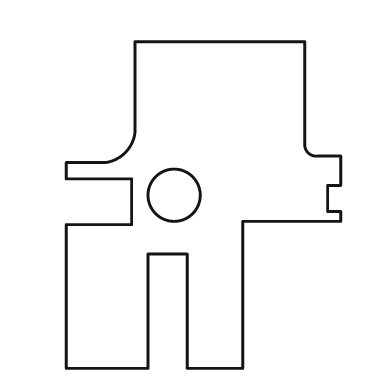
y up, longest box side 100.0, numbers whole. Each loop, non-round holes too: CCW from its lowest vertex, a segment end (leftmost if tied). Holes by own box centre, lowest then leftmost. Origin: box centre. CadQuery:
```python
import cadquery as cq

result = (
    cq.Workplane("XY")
    .moveTo(-42.0, -50.0)
    .lineTo(-17.0, -50.0)
    .lineTo(-17.0, -15.0)
    .lineTo(-5.0, -15.0)
    .lineTo(-5.0, -50.0)
    .lineTo(12.0, -50.0)
    .lineTo(12.0, -5.0)
    .lineTo(42.0, -5.0)
    .lineTo(42.0, -2.0)
    .lineTo(38.0, -2.0)
    .lineTo(38.0, 6.0)
    .lineTo(42.0, 6.0)
    .lineTo(42.0, 15.0)
    .lineTo(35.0, 15.0)
    .threePointArc((32.0, 16.0), (31.0, 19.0))
    .lineTo(31.0, 50.0)
    .lineTo(-21.0, 50.0)
    .lineTo(-21.0, 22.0)
    .threePointArc((-24.0, 16.0), (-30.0, 13.0))
    .lineTo(-42.0, 13.0)
    .lineTo(-42.0, 8.0)
    .lineTo(-22.0, 8.0)
    .lineTo(-22.0, -6.0)
    .lineTo(-42.0, -6.0)
    .close()
    .moveTo(-9.0, 3.0)
    .circle(8.0)
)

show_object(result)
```